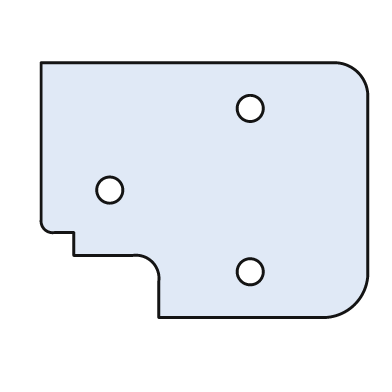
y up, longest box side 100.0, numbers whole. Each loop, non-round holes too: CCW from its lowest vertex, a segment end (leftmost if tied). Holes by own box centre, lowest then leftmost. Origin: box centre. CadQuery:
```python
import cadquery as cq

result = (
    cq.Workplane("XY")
    .moveTo(-14.0, -39.0)
    .lineTo(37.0, -39.0)
    .threePointArc((46.0, -35.0), (50.0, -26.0))
    .lineTo(50.0, 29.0)
    .threePointArc((47.0, 36.0), (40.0, 39.0))
    .lineTo(-50.0, 39.0)
    .lineTo(-50.0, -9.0)
    .threePointArc((-49.0, -12.0), (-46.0, -13.0))
    .lineTo(-40.0, -13.0)
    .lineTo(-40.0, -20.0)
    .lineTo(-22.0, -20.0)
    .threePointArc((-16.0, -22.0), (-14.0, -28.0))
    .close()
    .moveTo(14.0, -25.0)
    .circle(4.0)
    .moveTo(-29.0, 0.0)
    .circle(4.0)
    .moveTo(14.0, 25.0)
    .circle(4.0)
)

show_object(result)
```